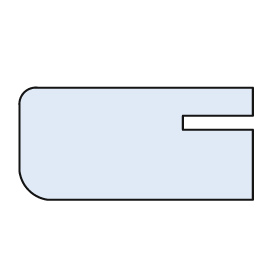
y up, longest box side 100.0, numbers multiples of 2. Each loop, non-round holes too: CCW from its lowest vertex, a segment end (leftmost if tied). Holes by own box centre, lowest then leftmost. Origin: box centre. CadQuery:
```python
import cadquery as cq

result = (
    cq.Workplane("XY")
    .moveTo(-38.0, -24.0)
    .lineTo(50.0, -24.0)
    .lineTo(50.0, 6.0)
    .lineTo(20.0, 6.0)
    .lineTo(20.0, 12.0)
    .lineTo(50.0, 12.0)
    .lineTo(50.0, 24.0)
    .lineTo(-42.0, 24.0)
    .threePointArc((-48.0, 22.0), (-50.0, 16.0))
    .lineTo(-50.0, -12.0)
    .threePointArc((-46.0, -20.0), (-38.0, -24.0))
    .close()
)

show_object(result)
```